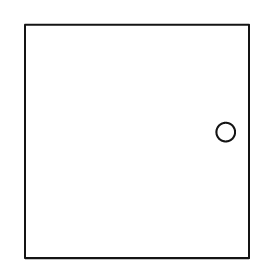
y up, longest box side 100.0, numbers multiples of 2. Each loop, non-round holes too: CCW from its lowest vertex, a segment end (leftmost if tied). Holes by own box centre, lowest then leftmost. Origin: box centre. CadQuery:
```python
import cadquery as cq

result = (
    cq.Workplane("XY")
    .moveTo(-48.0, -50.0)
    .lineTo(48.0, -50.0)
    .lineTo(48.0, 50.0)
    .lineTo(-48.0, 50.0)
    .close()
    .moveTo(38.0, 4.0)
    .circle(4.0)
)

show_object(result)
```